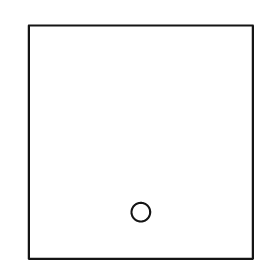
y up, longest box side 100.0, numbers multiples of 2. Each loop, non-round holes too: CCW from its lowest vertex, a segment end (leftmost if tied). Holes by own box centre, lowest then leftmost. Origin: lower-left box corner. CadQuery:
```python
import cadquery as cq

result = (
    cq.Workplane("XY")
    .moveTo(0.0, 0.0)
    .lineTo(96.0, 0.0)
    .lineTo(96.0, 100.0)
    .lineTo(0.0, 100.0)
    .close()
    .moveTo(48.0, 20.0)
    .circle(4.0)
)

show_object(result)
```